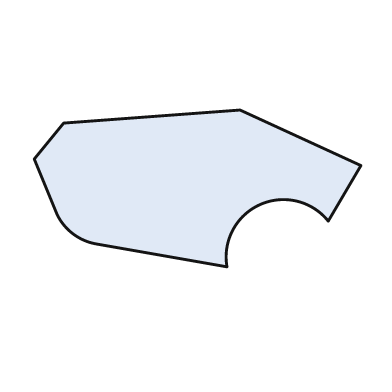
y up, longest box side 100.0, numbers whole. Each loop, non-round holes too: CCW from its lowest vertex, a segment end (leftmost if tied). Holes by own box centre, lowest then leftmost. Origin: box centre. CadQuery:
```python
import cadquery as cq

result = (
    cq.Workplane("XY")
    .moveTo(9.0, -24.0)
    .threePointArc((19.0, -5.0), (40.0, -10.0))
    .lineTo(50.0, 7.0)
    .lineTo(13.0, 24.0)
    .lineTo(-41.0, 20.0)
    .lineTo(-50.0, 9.0)
    .lineTo(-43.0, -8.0)
    .threePointArc((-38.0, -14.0), (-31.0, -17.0))
    .close()
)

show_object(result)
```